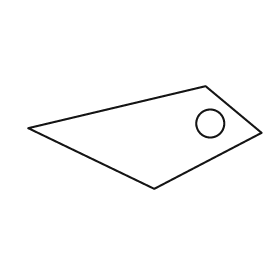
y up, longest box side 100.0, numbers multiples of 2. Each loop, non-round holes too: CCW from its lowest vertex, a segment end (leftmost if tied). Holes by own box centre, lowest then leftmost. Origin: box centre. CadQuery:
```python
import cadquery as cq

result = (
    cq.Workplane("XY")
    .moveTo(4.0, -22.0)
    .lineTo(50.0, 2.0)
    .lineTo(26.0, 22.0)
    .lineTo(-50.0, 4.0)
    .close()
    .moveTo(28.0, 6.0)
    .circle(6.0)
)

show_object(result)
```